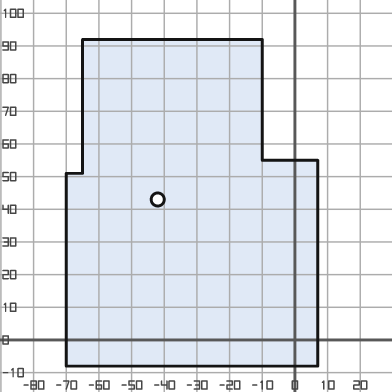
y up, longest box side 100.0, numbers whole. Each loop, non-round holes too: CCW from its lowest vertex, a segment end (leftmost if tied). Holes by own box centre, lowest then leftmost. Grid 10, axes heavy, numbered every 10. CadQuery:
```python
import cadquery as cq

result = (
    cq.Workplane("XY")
    .moveTo(-70.0, -8.0)
    .lineTo(7.0, -8.0)
    .lineTo(7.0, 55.0)
    .lineTo(-10.0, 55.0)
    .lineTo(-10.0, 92.0)
    .lineTo(-65.0, 92.0)
    .lineTo(-65.0, 51.0)
    .lineTo(-70.0, 51.0)
    .close()
    .moveTo(-42.0, 43.0)
    .circle(2.0)
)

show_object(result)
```